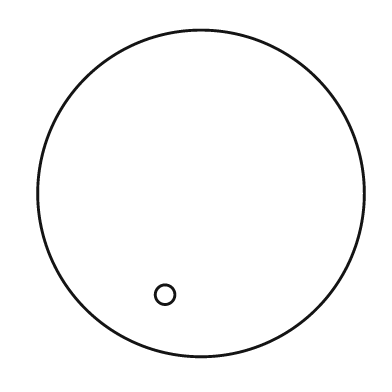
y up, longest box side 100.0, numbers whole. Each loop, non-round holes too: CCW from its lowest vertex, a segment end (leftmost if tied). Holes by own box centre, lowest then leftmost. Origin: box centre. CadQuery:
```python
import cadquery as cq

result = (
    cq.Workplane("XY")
    .moveTo(0.0, 0.0)
    .circle(50.0)
    .moveTo(-11.0, -31.0)
    .circle(3.0)
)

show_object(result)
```